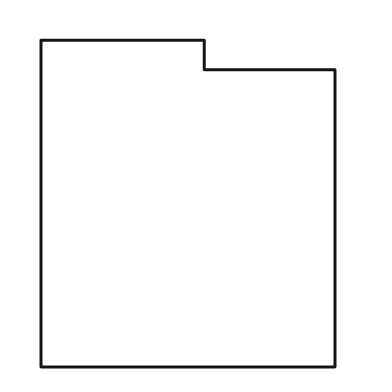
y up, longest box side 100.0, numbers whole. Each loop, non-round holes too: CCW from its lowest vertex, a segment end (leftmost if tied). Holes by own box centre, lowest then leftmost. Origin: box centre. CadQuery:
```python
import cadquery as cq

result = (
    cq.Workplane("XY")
    .moveTo(-45.0, -50.0)
    .lineTo(45.0, -50.0)
    .lineTo(45.0, 41.0)
    .lineTo(5.0, 41.0)
    .lineTo(5.0, 50.0)
    .lineTo(-45.0, 50.0)
    .close()
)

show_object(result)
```